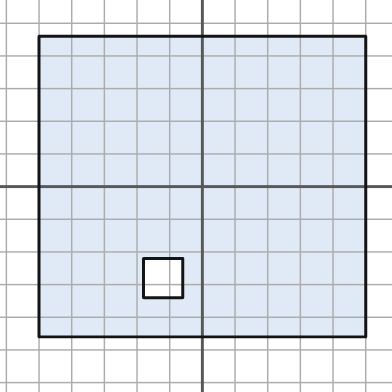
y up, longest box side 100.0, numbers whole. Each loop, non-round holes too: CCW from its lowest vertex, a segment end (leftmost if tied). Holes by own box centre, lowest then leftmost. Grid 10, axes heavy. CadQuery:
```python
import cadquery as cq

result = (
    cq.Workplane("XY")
    .moveTo(-50.0, -46.0)
    .lineTo(50.0, -46.0)
    .lineTo(50.0, 46.0)
    .lineTo(-50.0, 46.0)
    .close()
    .moveTo(-18.0, -34.0)
    .lineTo(-6.0, -34.0)
    .lineTo(-6.0, -22.0)
    .lineTo(-18.0, -22.0)
    .close()
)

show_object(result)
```